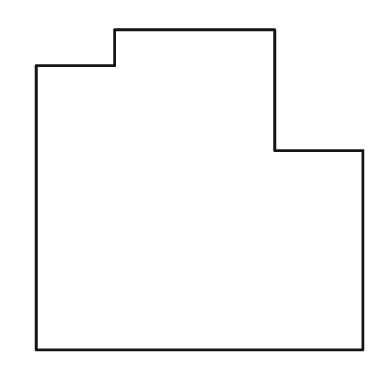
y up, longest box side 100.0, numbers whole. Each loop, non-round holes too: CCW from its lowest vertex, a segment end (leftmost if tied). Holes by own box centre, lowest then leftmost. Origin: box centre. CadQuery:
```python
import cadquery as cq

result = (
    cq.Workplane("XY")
    .moveTo(-50.0, -49.0)
    .lineTo(50.0, -49.0)
    .lineTo(50.0, 12.0)
    .lineTo(23.0, 12.0)
    .lineTo(23.0, 49.0)
    .lineTo(-26.0, 49.0)
    .lineTo(-26.0, 38.0)
    .lineTo(-50.0, 38.0)
    .close()
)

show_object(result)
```